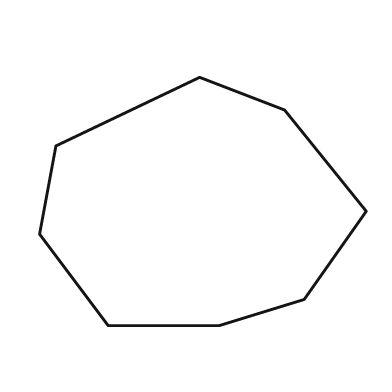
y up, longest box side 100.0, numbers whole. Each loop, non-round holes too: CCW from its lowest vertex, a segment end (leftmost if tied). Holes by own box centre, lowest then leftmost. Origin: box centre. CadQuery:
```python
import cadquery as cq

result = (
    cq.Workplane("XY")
    .moveTo(-29.0, -38.0)
    .lineTo(5.0, -38.0)
    .lineTo(31.0, -30.0)
    .lineTo(50.0, -3.0)
    .lineTo(25.0, 28.0)
    .lineTo(-1.0, 38.0)
    .lineTo(-45.0, 17.0)
    .lineTo(-50.0, -10.0)
    .close()
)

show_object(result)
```